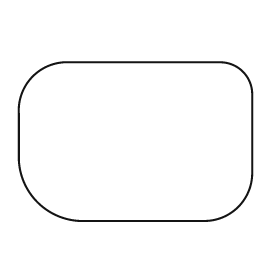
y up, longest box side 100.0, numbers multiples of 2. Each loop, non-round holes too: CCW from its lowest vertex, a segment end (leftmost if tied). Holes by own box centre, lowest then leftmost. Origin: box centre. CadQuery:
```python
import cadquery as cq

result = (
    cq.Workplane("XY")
    .moveTo(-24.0, -34.0)
    .lineTo(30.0, -34.0)
    .threePointArc((44.0, -28.0), (50.0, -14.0))
    .lineTo(50.0, 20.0)
    .threePointArc((46.0, 30.0), (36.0, 34.0))
    .lineTo(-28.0, 34.0)
    .threePointArc((-44.0, 28.0), (-50.0, 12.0))
    .lineTo(-50.0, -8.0)
    .threePointArc((-42.0, -26.0), (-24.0, -34.0))
    .close()
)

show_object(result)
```